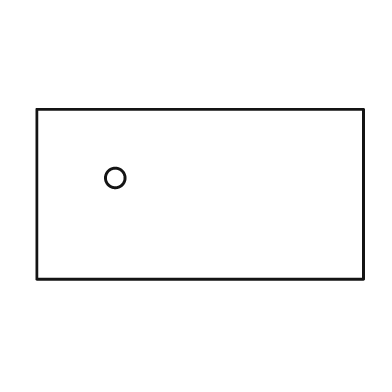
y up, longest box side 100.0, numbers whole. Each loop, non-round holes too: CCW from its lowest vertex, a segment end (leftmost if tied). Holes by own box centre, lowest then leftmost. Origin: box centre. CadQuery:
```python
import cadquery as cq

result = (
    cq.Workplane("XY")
    .moveTo(-50.0, -26.0)
    .lineTo(50.0, -26.0)
    .lineTo(50.0, 26.0)
    .lineTo(-50.0, 26.0)
    .close()
    .moveTo(-26.0, 5.0)
    .circle(3.0)
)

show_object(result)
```